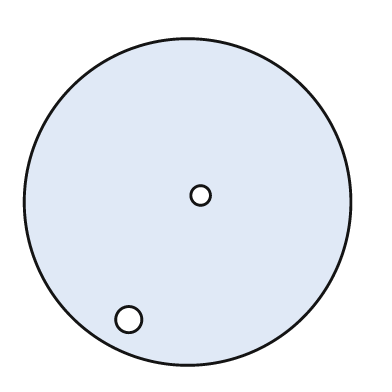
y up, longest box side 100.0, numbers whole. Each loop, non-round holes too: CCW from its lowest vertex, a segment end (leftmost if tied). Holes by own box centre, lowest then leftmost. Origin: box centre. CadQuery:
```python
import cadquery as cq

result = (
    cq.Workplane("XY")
    .moveTo(0.0, 0.0)
    .circle(50.0)
    .moveTo(-18.0, -36.0)
    .circle(4.0)
    .moveTo(4.0, 2.0)
    .circle(3.0)
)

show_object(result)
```